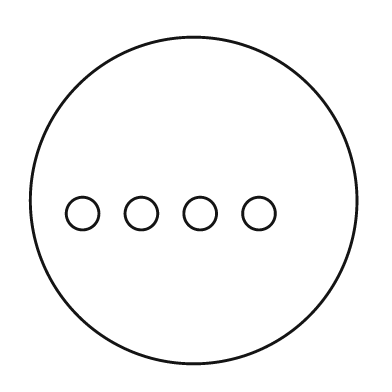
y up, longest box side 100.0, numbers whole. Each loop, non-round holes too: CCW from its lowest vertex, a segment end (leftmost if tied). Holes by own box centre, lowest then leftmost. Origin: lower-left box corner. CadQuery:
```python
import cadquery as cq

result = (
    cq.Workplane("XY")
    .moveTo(50.0, 50.0)
    .circle(50.0)
    .moveTo(16.0, 46.0)
    .circle(5.0)
    .moveTo(34.0, 46.0)
    .circle(5.0)
    .moveTo(52.0, 46.0)
    .circle(5.0)
    .moveTo(70.0, 46.0)
    .circle(5.0)
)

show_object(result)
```